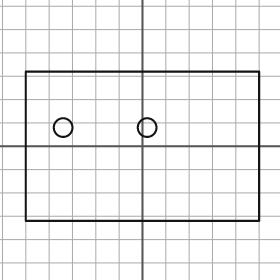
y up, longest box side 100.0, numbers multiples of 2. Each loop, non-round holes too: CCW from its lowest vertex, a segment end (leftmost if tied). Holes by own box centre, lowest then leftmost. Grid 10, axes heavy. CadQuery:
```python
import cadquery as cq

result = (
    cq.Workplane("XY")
    .moveTo(-50.0, -32.0)
    .lineTo(50.0, -32.0)
    .lineTo(50.0, 32.0)
    .lineTo(-50.0, 32.0)
    .close()
    .moveTo(-34.0, 8.0)
    .circle(4.0)
    .moveTo(2.0, 8.0)
    .circle(4.0)
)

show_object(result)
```